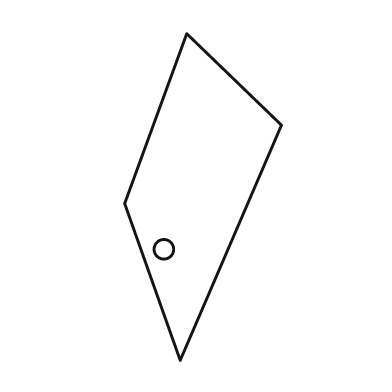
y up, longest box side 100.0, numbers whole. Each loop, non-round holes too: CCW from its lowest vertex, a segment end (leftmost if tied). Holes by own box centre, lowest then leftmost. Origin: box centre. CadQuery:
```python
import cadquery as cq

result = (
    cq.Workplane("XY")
    .moveTo(-7.0, -50.0)
    .lineTo(24.0, 22.0)
    .lineTo(-5.0, 50.0)
    .lineTo(-24.0, -2.0)
    .close()
    .moveTo(-12.0, -16.0)
    .circle(3.0)
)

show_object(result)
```